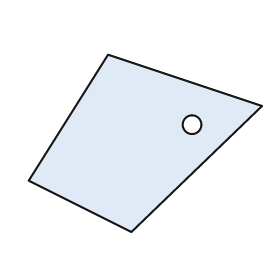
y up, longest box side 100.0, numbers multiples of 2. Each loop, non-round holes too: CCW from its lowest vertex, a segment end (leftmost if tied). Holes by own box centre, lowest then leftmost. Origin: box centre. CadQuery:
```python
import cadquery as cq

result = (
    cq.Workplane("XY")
    .moveTo(-6.0, -38.0)
    .lineTo(50.0, 16.0)
    .lineTo(-16.0, 38.0)
    .lineTo(-50.0, -16.0)
    .close()
    .moveTo(20.0, 8.0)
    .circle(4.0)
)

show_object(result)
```